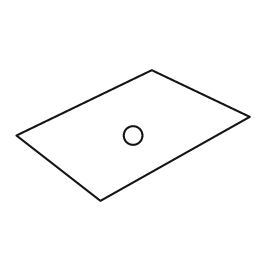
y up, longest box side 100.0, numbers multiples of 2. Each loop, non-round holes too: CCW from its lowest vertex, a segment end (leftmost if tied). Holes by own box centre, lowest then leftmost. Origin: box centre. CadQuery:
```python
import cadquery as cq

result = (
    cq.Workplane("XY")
    .moveTo(-14.0, -28.0)
    .lineTo(50.0, 8.0)
    .lineTo(8.0, 28.0)
    .lineTo(-50.0, 0.0)
    .close()
    .moveTo(0.0, 0.0)
    .circle(4.0)
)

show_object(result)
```